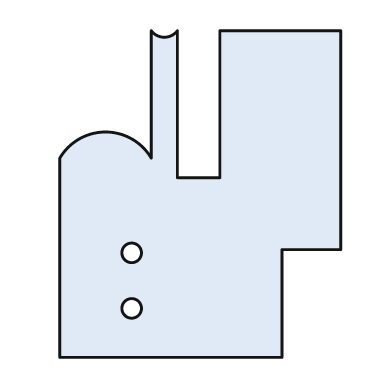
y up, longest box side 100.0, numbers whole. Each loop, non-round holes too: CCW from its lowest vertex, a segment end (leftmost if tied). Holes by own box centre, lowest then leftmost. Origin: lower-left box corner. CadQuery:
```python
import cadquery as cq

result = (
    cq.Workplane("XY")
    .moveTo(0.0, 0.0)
    .lineTo(68.0, 0.0)
    .lineTo(68.0, 33.0)
    .lineTo(86.0, 33.0)
    .lineTo(86.0, 100.0)
    .lineTo(49.0, 100.0)
    .lineTo(49.0, 55.0)
    .lineTo(36.0, 55.0)
    .lineTo(36.0, 100.0)
    .threePointArc((32.0, 98.0), (28.0, 100.0))
    .lineTo(28.0, 61.0)
    .threePointArc((14.0, 69.0), (0.0, 61.0))
    .close()
    .moveTo(22.0, 15.0)
    .circle(3.0)
    .moveTo(22.0, 32.0)
    .circle(3.0)
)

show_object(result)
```